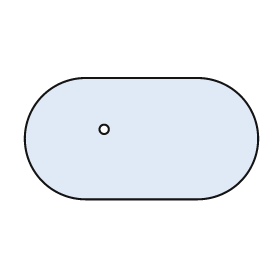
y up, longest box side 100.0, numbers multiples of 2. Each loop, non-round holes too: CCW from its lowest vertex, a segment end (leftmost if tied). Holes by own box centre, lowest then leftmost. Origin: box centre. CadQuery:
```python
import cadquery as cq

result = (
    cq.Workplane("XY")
    .moveTo(-24.0, -26.0)
    .lineTo(24.0, -26.0)
    .threePointArc((50.0, 0.0), (24.0, 26.0))
    .lineTo(-24.0, 26.0)
    .threePointArc((-50.0, 0.0), (-24.0, -26.0))
    .close()
    .moveTo(-16.0, 4.0)
    .circle(2.0)
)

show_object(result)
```